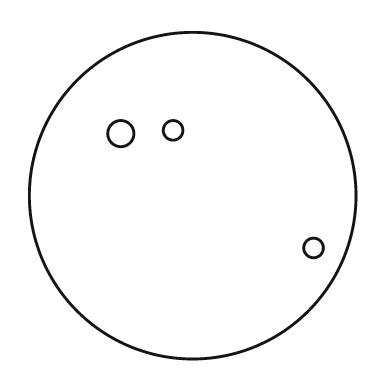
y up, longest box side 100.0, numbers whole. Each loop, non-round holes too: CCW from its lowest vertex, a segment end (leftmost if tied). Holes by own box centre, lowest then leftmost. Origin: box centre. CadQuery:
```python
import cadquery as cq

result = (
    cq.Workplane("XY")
    .moveTo(0.0, 0.0)
    .circle(50.0)
    .moveTo(37.0, -16.0)
    .circle(3.0)
    .moveTo(-22.0, 19.0)
    .circle(4.0)
    .moveTo(-6.0, 20.0)
    .circle(3.0)
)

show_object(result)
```